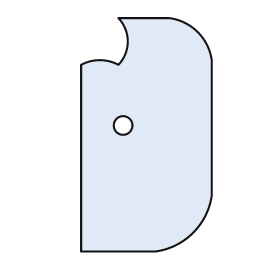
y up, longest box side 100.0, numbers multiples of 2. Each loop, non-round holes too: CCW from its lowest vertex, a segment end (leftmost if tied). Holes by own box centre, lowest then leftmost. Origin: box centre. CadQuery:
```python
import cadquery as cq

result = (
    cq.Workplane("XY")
    .moveTo(-28.0, -50.0)
    .lineTo(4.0, -50.0)
    .threePointArc((20.0, -42.0), (28.0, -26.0))
    .lineTo(28.0, 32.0)
    .threePointArc((22.0, 44.0), (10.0, 50.0))
    .lineTo(-12.0, 50.0)
    .threePointArc((-8.0, 40.0), (-12.0, 30.0))
    .threePointArc((-20.0, 32.0), (-28.0, 30.0))
    .close()
    .moveTo(-10.0, 4.0)
    .circle(4.0)
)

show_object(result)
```